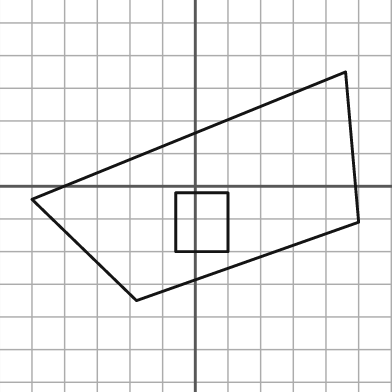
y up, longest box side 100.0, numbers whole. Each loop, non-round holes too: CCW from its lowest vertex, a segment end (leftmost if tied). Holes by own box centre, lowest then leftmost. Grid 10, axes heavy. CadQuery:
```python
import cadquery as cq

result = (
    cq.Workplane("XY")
    .moveTo(-18.0, -35.0)
    .lineTo(50.0, -11.0)
    .lineTo(46.0, 35.0)
    .lineTo(-50.0, -4.0)
    .close()
    .moveTo(-6.0, -20.0)
    .lineTo(10.0, -20.0)
    .lineTo(10.0, -2.0)
    .lineTo(-6.0, -2.0)
    .close()
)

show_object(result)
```